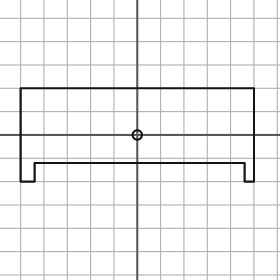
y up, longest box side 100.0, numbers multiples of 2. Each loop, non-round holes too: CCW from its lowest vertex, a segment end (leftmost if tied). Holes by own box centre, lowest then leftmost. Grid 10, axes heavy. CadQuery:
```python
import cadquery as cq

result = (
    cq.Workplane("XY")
    .moveTo(-50.0, -20.0)
    .lineTo(-44.0, -20.0)
    .lineTo(-44.0, -12.0)
    .lineTo(46.0, -12.0)
    .lineTo(46.0, -20.0)
    .lineTo(50.0, -20.0)
    .lineTo(50.0, 20.0)
    .lineTo(-50.0, 20.0)
    .close()
    .moveTo(0.0, 0.0)
    .circle(2.0)
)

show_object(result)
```